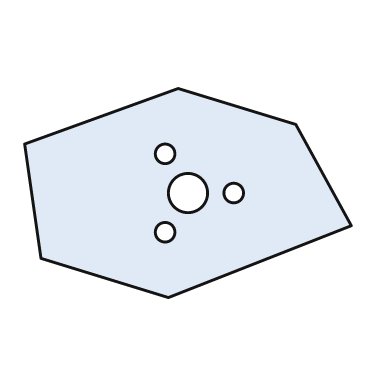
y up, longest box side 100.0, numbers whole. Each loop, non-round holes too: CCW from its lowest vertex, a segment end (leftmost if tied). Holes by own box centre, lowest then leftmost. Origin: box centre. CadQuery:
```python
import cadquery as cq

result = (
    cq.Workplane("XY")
    .moveTo(-6.0, -32.0)
    .lineTo(50.0, -10.0)
    .lineTo(33.0, 21.0)
    .lineTo(-3.0, 32.0)
    .lineTo(-50.0, 15.0)
    .lineTo(-45.0, -20.0)
    .close()
    .moveTo(-7.0, -12.0)
    .circle(3.0)
    .moveTo(0.0, 0.0)
    .circle(6.0)
    .moveTo(14.0, 0.0)
    .circle(3.0)
    .moveTo(-7.0, 12.0)
    .circle(3.0)
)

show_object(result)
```